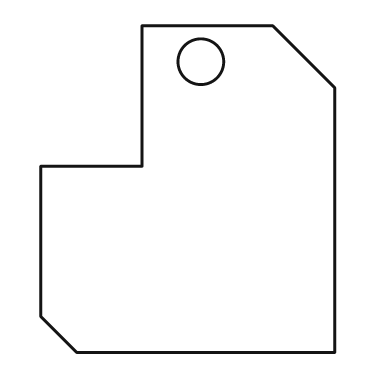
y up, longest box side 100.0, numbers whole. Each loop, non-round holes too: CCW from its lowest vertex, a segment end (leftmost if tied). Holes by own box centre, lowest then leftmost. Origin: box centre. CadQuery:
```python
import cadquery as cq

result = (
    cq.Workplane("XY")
    .moveTo(-34.0, -50.0)
    .lineTo(45.0, -50.0)
    .lineTo(45.0, 31.0)
    .lineTo(26.0, 50.0)
    .lineTo(-14.0, 50.0)
    .lineTo(-14.0, 7.0)
    .lineTo(-45.0, 7.0)
    .lineTo(-45.0, -39.0)
    .close()
    .moveTo(4.0, 39.0)
    .circle(7.0)
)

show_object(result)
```